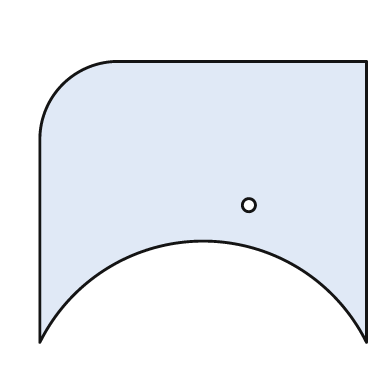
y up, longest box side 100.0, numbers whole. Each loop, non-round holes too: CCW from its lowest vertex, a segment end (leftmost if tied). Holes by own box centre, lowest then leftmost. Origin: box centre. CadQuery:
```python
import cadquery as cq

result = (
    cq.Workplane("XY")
    .moveTo(-50.0, -43.0)
    .threePointArc((0.0, -12.0), (50.0, -43.0))
    .lineTo(50.0, 43.0)
    .lineTo(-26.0, 43.0)
    .threePointArc((-43.0, 36.0), (-50.0, 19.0))
    .close()
    .moveTo(14.0, -1.0)
    .circle(2.0)
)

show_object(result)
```